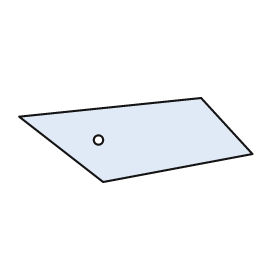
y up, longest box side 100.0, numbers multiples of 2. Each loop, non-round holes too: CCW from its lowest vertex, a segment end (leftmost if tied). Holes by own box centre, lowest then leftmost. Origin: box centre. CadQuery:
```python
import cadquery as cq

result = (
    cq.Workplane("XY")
    .moveTo(-14.0, -18.0)
    .lineTo(50.0, -6.0)
    .lineTo(28.0, 18.0)
    .lineTo(-50.0, 10.0)
    .close()
    .moveTo(-16.0, 0.0)
    .circle(2.0)
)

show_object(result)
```